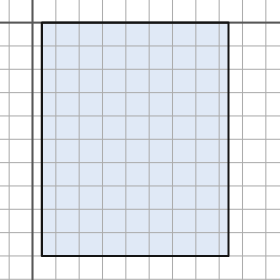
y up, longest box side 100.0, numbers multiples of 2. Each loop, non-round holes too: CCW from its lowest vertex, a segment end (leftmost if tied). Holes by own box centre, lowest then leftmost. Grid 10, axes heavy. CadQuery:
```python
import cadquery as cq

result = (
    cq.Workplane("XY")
    .moveTo(4.0, -100.0)
    .lineTo(84.0, -100.0)
    .lineTo(84.0, 0.0)
    .lineTo(4.0, 0.0)
    .close()
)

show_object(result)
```